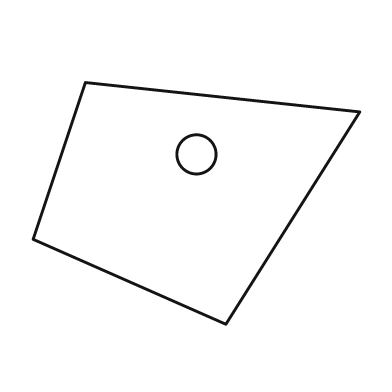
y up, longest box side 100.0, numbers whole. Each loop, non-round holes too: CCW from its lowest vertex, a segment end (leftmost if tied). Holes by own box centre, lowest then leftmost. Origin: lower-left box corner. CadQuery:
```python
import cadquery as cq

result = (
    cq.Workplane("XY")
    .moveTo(59.0, 0.0)
    .lineTo(100.0, 65.0)
    .lineTo(16.0, 74.0)
    .lineTo(0.0, 26.0)
    .close()
    .moveTo(50.0, 52.0)
    .circle(6.0)
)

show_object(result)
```